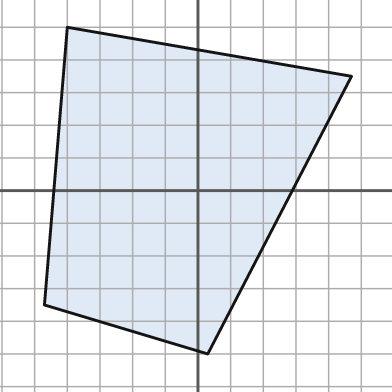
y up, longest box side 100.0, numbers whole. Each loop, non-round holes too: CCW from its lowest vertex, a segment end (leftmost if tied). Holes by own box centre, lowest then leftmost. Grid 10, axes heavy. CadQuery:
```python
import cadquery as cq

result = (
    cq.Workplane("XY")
    .moveTo(3.0, -50.0)
    .lineTo(47.0, 35.0)
    .lineTo(-40.0, 50.0)
    .lineTo(-47.0, -35.0)
    .close()
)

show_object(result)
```